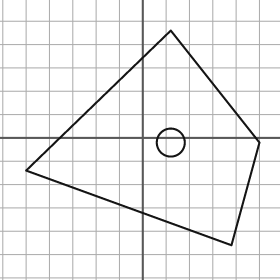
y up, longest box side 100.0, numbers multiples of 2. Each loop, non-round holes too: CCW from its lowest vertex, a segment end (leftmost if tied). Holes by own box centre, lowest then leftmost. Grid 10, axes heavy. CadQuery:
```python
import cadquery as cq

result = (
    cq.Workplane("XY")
    .moveTo(38.0, -46.0)
    .lineTo(50.0, -2.0)
    .lineTo(12.0, 46.0)
    .lineTo(-50.0, -14.0)
    .close()
    .moveTo(12.0, -2.0)
    .circle(6.0)
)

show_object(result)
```